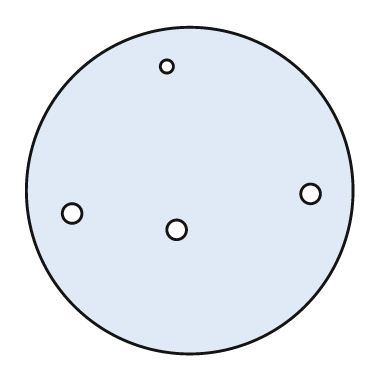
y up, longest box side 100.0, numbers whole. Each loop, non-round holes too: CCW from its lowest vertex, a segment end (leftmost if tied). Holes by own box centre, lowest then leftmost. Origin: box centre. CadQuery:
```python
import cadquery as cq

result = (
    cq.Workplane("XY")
    .moveTo(0.0, 0.0)
    .circle(50.0)
    .moveTo(-4.0, -12.0)
    .circle(3.0)
    .moveTo(-36.0, -7.0)
    .circle(3.0)
    .moveTo(37.0, -1.0)
    .circle(3.0)
    .moveTo(-7.0, 38.0)
    .circle(2.0)
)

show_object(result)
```